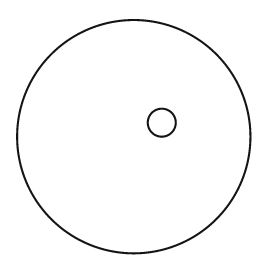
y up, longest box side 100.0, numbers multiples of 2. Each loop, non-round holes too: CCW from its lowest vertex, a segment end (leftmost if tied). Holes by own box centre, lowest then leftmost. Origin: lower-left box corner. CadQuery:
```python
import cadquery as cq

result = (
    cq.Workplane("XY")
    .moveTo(50.0, 50.0)
    .circle(50.0)
    .moveTo(62.0, 56.0)
    .circle(6.0)
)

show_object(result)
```